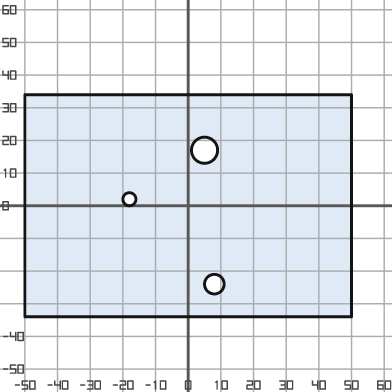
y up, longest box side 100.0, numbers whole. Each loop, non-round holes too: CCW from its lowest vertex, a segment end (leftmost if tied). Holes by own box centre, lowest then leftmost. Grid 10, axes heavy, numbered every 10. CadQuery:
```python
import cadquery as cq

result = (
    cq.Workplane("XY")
    .moveTo(-50.0, -34.0)
    .lineTo(50.0, -34.0)
    .lineTo(50.0, 34.0)
    .lineTo(-50.0, 34.0)
    .close()
    .moveTo(8.0, -24.0)
    .circle(3.0)
    .moveTo(-18.0, 2.0)
    .circle(2.0)
    .moveTo(5.0, 17.0)
    .circle(4.0)
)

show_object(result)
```